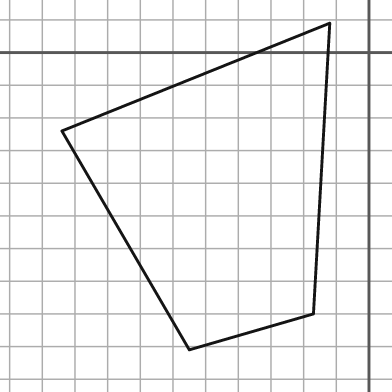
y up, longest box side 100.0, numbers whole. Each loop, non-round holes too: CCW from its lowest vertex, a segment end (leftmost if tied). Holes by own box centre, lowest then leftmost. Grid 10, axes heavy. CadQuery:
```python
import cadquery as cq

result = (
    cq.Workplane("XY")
    .moveTo(-55.0, -91.0)
    .lineTo(-17.0, -80.0)
    .lineTo(-12.0, 9.0)
    .lineTo(-94.0, -24.0)
    .close()
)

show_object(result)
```